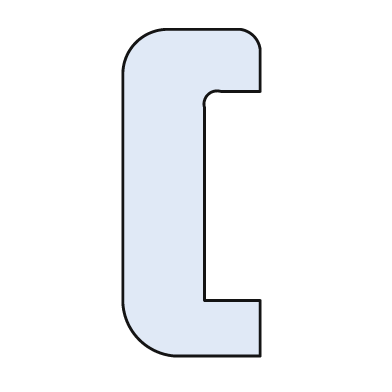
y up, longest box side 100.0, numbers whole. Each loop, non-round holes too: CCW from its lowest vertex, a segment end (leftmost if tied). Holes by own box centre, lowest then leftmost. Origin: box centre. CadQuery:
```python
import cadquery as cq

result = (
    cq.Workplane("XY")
    .moveTo(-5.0, -50.0)
    .lineTo(21.0, -50.0)
    .lineTo(21.0, -33.0)
    .lineTo(4.0, -33.0)
    .lineTo(4.0, 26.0)
    .threePointArc((5.0, 30.0), (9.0, 31.0))
    .lineTo(21.0, 31.0)
    .lineTo(21.0, 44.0)
    .threePointArc((19.0, 48.0), (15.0, 50.0))
    .lineTo(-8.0, 50.0)
    .threePointArc((-17.0, 46.0), (-21.0, 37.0))
    .lineTo(-21.0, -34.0)
    .threePointArc((-16.0, -45.0), (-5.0, -50.0))
    .close()
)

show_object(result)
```